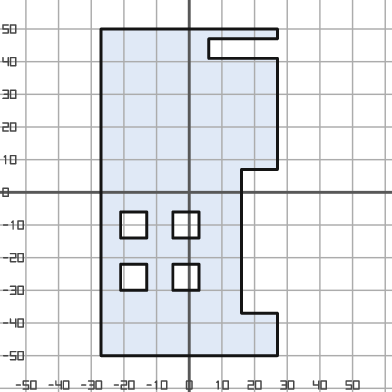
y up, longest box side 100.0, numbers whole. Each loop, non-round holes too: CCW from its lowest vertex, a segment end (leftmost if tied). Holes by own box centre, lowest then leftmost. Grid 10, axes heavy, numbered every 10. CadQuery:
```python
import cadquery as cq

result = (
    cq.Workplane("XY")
    .moveTo(-27.0, -50.0)
    .lineTo(27.0, -50.0)
    .lineTo(27.0, -37.0)
    .lineTo(16.0, -37.0)
    .lineTo(16.0, 7.0)
    .lineTo(27.0, 7.0)
    .lineTo(27.0, 41.0)
    .lineTo(6.0, 41.0)
    .lineTo(6.0, 47.0)
    .lineTo(27.0, 47.0)
    .lineTo(27.0, 50.0)
    .lineTo(-27.0, 50.0)
    .close()
    .moveTo(-21.0, -30.0)
    .lineTo(-13.0, -30.0)
    .lineTo(-13.0, -22.0)
    .lineTo(-21.0, -22.0)
    .close()
    .moveTo(-5.0, -30.0)
    .lineTo(3.0, -30.0)
    .lineTo(3.0, -22.0)
    .lineTo(-5.0, -22.0)
    .close()
    .moveTo(-21.0, -14.0)
    .lineTo(-13.0, -14.0)
    .lineTo(-13.0, -6.0)
    .lineTo(-21.0, -6.0)
    .close()
    .moveTo(-5.0, -14.0)
    .lineTo(3.0, -14.0)
    .lineTo(3.0, -6.0)
    .lineTo(-5.0, -6.0)
    .close()
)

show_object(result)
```